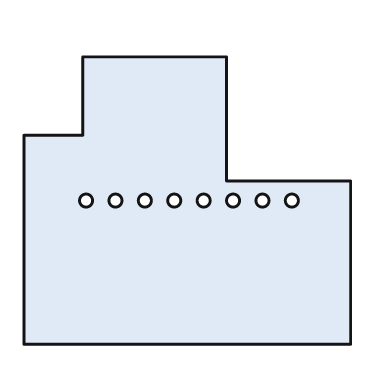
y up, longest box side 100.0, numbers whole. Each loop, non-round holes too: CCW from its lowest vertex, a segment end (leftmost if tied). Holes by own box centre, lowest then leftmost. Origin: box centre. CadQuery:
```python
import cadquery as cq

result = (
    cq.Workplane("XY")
    .moveTo(-50.0, -44.0)
    .lineTo(50.0, -44.0)
    .lineTo(50.0, 6.0)
    .lineTo(12.0, 6.0)
    .lineTo(12.0, 44.0)
    .lineTo(-32.0, 44.0)
    .lineTo(-32.0, 20.0)
    .lineTo(-50.0, 20.0)
    .close()
    .moveTo(-31.0, 0.0)
    .circle(2.0)
    .moveTo(-22.0, 0.0)
    .circle(2.0)
    .moveTo(-13.0, 0.0)
    .circle(2.0)
    .moveTo(-4.0, 0.0)
    .circle(2.0)
    .moveTo(5.0, 0.0)
    .circle(2.0)
    .moveTo(14.0, 0.0)
    .circle(2.0)
    .moveTo(23.0, 0.0)
    .circle(2.0)
    .moveTo(32.0, 0.0)
    .circle(2.0)
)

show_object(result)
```